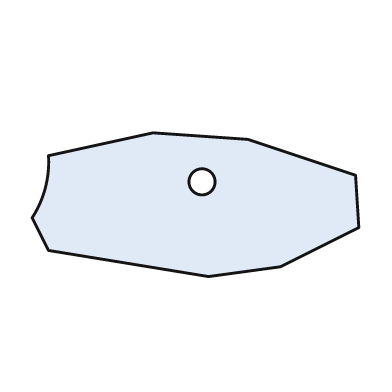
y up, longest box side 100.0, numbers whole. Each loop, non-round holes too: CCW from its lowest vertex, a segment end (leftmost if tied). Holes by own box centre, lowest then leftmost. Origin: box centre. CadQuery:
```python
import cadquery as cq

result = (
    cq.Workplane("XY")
    .moveTo(4.0, -22.0)
    .lineTo(26.0, -19.0)
    .lineTo(50.0, -7.0)
    .lineTo(49.0, 9.0)
    .lineTo(16.0, 20.0)
    .lineTo(-13.0, 22.0)
    .lineTo(-45.0, 15.0)
    .threePointArc((-46.0, 5.0), (-50.0, -4.0))
    .lineTo(-45.0, -14.0)
    .close()
    .moveTo(2.0, 7.0)
    .circle(4.0)
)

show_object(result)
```